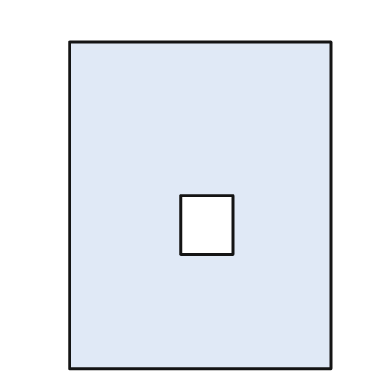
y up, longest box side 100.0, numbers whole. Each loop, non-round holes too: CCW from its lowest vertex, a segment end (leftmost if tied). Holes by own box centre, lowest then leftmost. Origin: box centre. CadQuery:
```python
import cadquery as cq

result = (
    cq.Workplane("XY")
    .moveTo(-40.0, -50.0)
    .lineTo(40.0, -50.0)
    .lineTo(40.0, 50.0)
    .lineTo(-40.0, 50.0)
    .close()
    .moveTo(-6.0, -15.0)
    .lineTo(10.0, -15.0)
    .lineTo(10.0, 3.0)
    .lineTo(-6.0, 3.0)
    .close()
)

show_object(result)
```